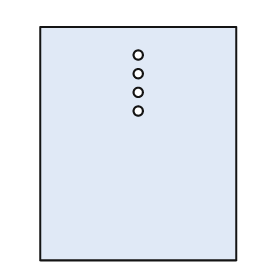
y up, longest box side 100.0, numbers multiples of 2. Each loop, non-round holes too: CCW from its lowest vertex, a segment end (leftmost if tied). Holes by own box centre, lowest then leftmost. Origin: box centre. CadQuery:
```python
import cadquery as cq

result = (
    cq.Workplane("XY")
    .moveTo(-42.0, -50.0)
    .lineTo(42.0, -50.0)
    .lineTo(42.0, 50.0)
    .lineTo(-42.0, 50.0)
    .close()
    .moveTo(0.0, 14.0)
    .circle(2.0)
    .moveTo(0.0, 22.0)
    .circle(2.0)
    .moveTo(0.0, 30.0)
    .circle(2.0)
    .moveTo(0.0, 38.0)
    .circle(2.0)
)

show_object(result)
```